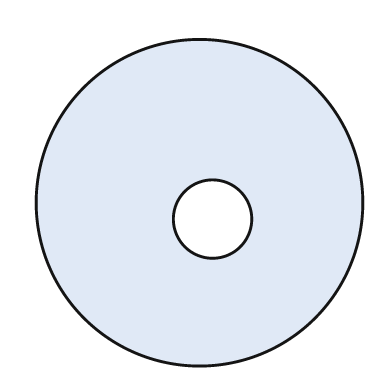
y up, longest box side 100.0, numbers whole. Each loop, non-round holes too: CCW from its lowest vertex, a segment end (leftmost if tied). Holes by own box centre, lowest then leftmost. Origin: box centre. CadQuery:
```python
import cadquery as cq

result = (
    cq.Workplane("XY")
    .moveTo(0.0, 0.0)
    .circle(50.0)
    .moveTo(4.0, -5.0)
    .circle(12.0)
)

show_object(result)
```